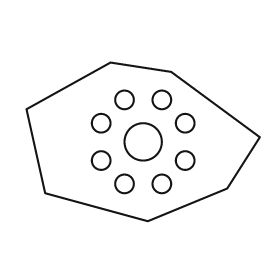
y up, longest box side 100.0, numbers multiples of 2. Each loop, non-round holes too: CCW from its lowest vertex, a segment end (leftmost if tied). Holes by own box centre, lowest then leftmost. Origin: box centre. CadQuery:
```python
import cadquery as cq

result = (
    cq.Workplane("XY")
    .moveTo(2.0, -34.0)
    .lineTo(36.0, -20.0)
    .lineTo(50.0, 2.0)
    .lineTo(12.0, 30.0)
    .lineTo(-14.0, 34.0)
    .lineTo(-50.0, 14.0)
    .lineTo(-42.0, -22.0)
    .close()
    .moveTo(-8.0, -18.0)
    .circle(4.0)
    .moveTo(8.0, -18.0)
    .circle(4.0)
    .moveTo(-18.0, -8.0)
    .circle(4.0)
    .moveTo(18.0, -8.0)
    .circle(4.0)
    .moveTo(0.0, 0.0)
    .circle(8.0)
    .moveTo(-18.0, 8.0)
    .circle(4.0)
    .moveTo(18.0, 8.0)
    .circle(4.0)
    .moveTo(-8.0, 18.0)
    .circle(4.0)
    .moveTo(8.0, 18.0)
    .circle(4.0)
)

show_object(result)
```